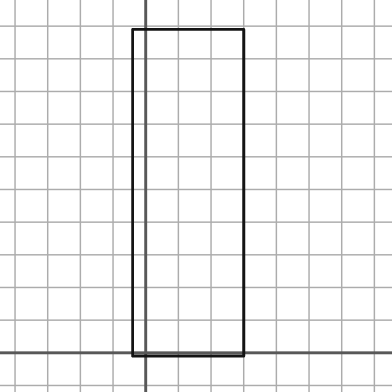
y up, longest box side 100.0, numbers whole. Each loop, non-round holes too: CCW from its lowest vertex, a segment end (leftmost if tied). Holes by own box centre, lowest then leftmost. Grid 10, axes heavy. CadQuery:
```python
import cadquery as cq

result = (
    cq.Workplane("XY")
    .moveTo(-4.0, -1.0)
    .lineTo(30.0, -1.0)
    .lineTo(30.0, 99.0)
    .lineTo(-4.0, 99.0)
    .close()
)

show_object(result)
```